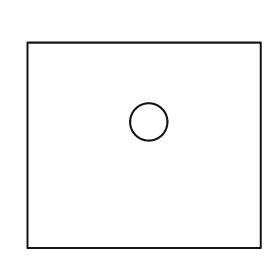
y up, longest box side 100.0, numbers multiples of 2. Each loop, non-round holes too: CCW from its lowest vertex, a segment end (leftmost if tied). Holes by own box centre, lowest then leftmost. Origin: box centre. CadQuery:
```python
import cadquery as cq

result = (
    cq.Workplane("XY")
    .moveTo(-50.0, -44.0)
    .lineTo(50.0, -44.0)
    .lineTo(50.0, 44.0)
    .lineTo(-50.0, 44.0)
    .close()
    .moveTo(2.0, 10.0)
    .circle(8.0)
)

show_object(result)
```